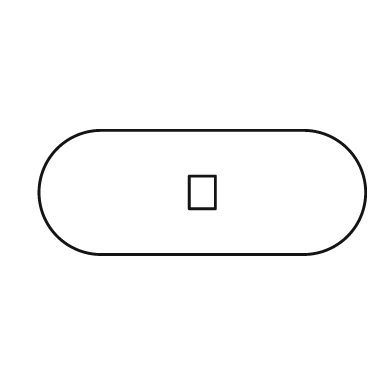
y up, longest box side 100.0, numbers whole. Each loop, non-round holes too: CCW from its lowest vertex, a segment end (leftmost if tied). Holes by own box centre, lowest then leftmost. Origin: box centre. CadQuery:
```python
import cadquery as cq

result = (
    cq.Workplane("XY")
    .moveTo(-31.0, -19.0)
    .lineTo(31.0, -19.0)
    .threePointArc((50.0, 0.0), (31.0, 19.0))
    .lineTo(-31.0, 19.0)
    .threePointArc((-50.0, 0.0), (-31.0, -19.0))
    .close()
    .moveTo(-4.0, -5.0)
    .lineTo(4.0, -5.0)
    .lineTo(4.0, 5.0)
    .lineTo(-4.0, 5.0)
    .close()
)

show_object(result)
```